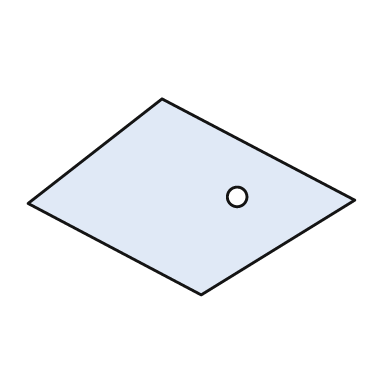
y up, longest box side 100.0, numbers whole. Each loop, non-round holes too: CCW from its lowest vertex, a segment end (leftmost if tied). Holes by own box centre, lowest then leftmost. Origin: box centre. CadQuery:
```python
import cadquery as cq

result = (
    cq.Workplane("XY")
    .moveTo(3.0, -30.0)
    .lineTo(50.0, -1.0)
    .lineTo(-9.0, 30.0)
    .lineTo(-50.0, -2.0)
    .close()
    .moveTo(14.0, 0.0)
    .circle(3.0)
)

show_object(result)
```